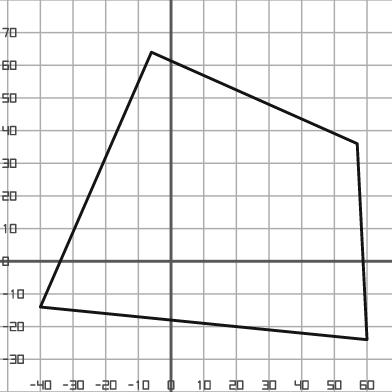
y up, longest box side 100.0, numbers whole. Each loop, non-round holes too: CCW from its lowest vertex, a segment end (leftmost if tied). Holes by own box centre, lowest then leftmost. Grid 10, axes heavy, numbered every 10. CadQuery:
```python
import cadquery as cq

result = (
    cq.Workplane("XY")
    .moveTo(60.0, -24.0)
    .lineTo(57.0, 36.0)
    .lineTo(-6.0, 64.0)
    .lineTo(-40.0, -14.0)
    .close()
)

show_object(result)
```